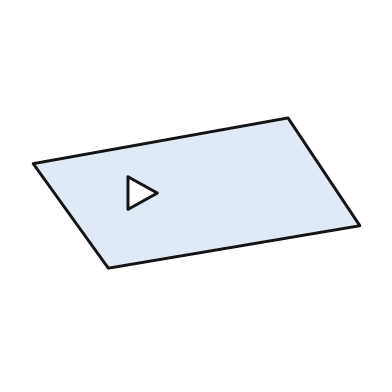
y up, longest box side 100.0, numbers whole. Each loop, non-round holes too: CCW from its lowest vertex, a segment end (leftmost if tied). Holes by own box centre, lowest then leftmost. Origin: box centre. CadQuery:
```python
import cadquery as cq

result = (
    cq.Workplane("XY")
    .moveTo(-27.0, -23.0)
    .lineTo(50.0, -10.0)
    .lineTo(28.0, 23.0)
    .lineTo(-50.0, 9.0)
    .close()
    .moveTo(-21.0, -5.0)
    .lineTo(-12.0, 0.0)
    .lineTo(-21.0, 5.0)
    .close()
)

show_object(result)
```